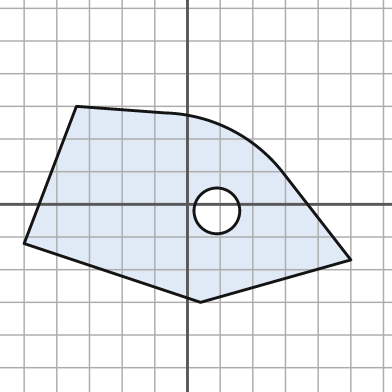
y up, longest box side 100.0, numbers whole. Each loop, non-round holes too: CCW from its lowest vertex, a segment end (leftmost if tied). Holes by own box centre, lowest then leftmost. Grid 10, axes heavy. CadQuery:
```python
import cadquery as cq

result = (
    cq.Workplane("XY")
    .moveTo(4.0, -30.0)
    .lineTo(50.0, -17.0)
    .lineTo(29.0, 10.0)
    .threePointArc((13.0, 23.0), (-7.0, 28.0))
    .lineTo(-34.0, 30.0)
    .lineTo(-50.0, -12.0)
    .close()
    .moveTo(9.0, -2.0)
    .circle(7.0)
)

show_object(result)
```